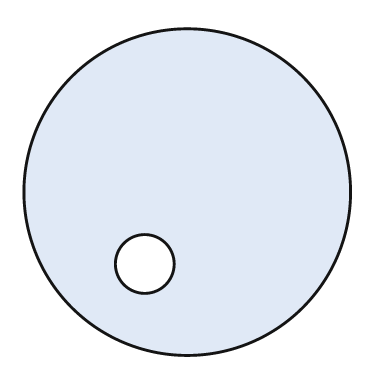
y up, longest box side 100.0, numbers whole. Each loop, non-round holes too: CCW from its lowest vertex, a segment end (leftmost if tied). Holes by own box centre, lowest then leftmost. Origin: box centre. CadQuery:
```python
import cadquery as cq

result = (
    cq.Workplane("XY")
    .moveTo(0.0, 0.0)
    .circle(50.0)
    .moveTo(-13.0, -22.0)
    .circle(9.0)
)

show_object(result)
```